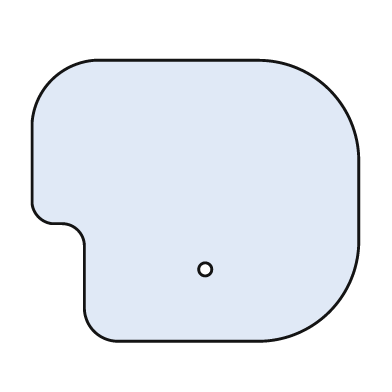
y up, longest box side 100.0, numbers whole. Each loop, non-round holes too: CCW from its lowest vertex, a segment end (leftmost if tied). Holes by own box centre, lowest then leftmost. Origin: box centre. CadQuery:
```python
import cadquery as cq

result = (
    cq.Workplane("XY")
    .moveTo(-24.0, -43.0)
    .lineTo(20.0, -43.0)
    .threePointArc((41.0, -34.0), (50.0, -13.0))
    .lineTo(50.0, 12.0)
    .threePointArc((41.0, 34.0), (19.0, 43.0))
    .lineTo(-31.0, 43.0)
    .threePointArc((-44.0, 37.0), (-50.0, 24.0))
    .lineTo(-50.0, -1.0)
    .threePointArc((-48.0, -5.0), (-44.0, -7.0))
    .lineTo(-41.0, -7.0)
    .threePointArc((-36.0, -9.0), (-34.0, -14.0))
    .lineTo(-34.0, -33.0)
    .threePointArc((-31.0, -40.0), (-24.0, -43.0))
    .close()
    .moveTo(3.0, -21.0)
    .circle(2.0)
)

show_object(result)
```